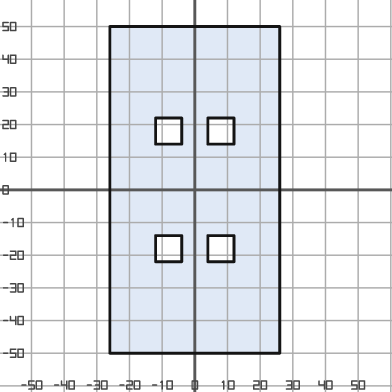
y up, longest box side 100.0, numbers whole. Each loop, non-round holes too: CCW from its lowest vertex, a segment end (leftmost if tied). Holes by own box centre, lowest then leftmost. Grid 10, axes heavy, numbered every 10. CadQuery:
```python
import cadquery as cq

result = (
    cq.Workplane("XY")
    .moveTo(-26.0, -50.0)
    .lineTo(26.0, -50.0)
    .lineTo(26.0, 50.0)
    .lineTo(-26.0, 50.0)
    .close()
    .moveTo(-12.0, -22.0)
    .lineTo(-4.0, -22.0)
    .lineTo(-4.0, -14.0)
    .lineTo(-12.0, -14.0)
    .close()
    .moveTo(4.0, -22.0)
    .lineTo(12.0, -22.0)
    .lineTo(12.0, -14.0)
    .lineTo(4.0, -14.0)
    .close()
    .moveTo(-12.0, 14.0)
    .lineTo(-4.0, 14.0)
    .lineTo(-4.0, 22.0)
    .lineTo(-12.0, 22.0)
    .close()
    .moveTo(4.0, 14.0)
    .lineTo(12.0, 14.0)
    .lineTo(12.0, 22.0)
    .lineTo(4.0, 22.0)
    .close()
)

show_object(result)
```